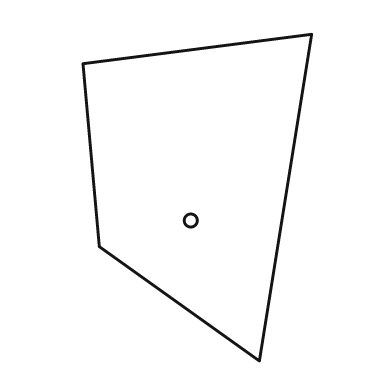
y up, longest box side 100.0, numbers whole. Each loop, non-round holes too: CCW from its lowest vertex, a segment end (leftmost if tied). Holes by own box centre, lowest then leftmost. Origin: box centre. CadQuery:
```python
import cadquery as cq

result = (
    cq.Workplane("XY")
    .moveTo(19.0, -50.0)
    .lineTo(35.0, 50.0)
    .lineTo(-35.0, 41.0)
    .lineTo(-30.0, -15.0)
    .close()
    .moveTo(-2.0, -7.0)
    .circle(2.0)
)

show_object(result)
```